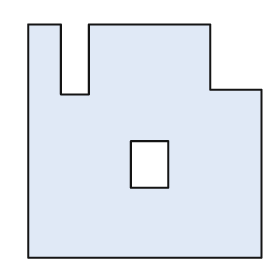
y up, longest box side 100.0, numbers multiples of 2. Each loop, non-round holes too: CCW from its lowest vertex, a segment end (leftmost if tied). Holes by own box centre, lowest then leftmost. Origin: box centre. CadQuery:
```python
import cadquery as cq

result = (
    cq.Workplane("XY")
    .moveTo(-50.0, -50.0)
    .lineTo(50.0, -50.0)
    .lineTo(50.0, 22.0)
    .lineTo(28.0, 22.0)
    .lineTo(28.0, 50.0)
    .lineTo(-24.0, 50.0)
    .lineTo(-24.0, 20.0)
    .lineTo(-36.0, 20.0)
    .lineTo(-36.0, 50.0)
    .lineTo(-50.0, 50.0)
    .close()
    .moveTo(-6.0, -20.0)
    .lineTo(10.0, -20.0)
    .lineTo(10.0, 0.0)
    .lineTo(-6.0, 0.0)
    .close()
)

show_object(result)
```